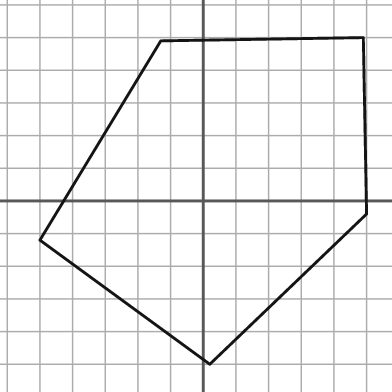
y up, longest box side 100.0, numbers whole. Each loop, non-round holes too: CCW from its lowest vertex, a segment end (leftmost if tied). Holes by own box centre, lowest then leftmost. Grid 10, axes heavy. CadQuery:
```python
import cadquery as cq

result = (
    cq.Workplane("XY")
    .moveTo(2.0, -50.0)
    .lineTo(50.0, -4.0)
    .lineTo(49.0, 50.0)
    .lineTo(-13.0, 49.0)
    .lineTo(-50.0, -12.0)
    .close()
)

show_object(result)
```